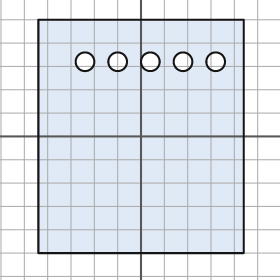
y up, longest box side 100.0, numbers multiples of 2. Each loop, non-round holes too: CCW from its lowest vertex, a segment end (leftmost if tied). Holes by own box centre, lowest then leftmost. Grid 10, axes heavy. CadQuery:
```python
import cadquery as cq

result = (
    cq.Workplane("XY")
    .moveTo(-44.0, -50.0)
    .lineTo(44.0, -50.0)
    .lineTo(44.0, 50.0)
    .lineTo(-44.0, 50.0)
    .close()
    .moveTo(-24.0, 32.0)
    .circle(4.0)
    .moveTo(-10.0, 32.0)
    .circle(4.0)
    .moveTo(4.0, 32.0)
    .circle(4.0)
    .moveTo(18.0, 32.0)
    .circle(4.0)
    .moveTo(32.0, 32.0)
    .circle(4.0)
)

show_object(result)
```